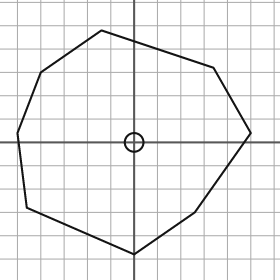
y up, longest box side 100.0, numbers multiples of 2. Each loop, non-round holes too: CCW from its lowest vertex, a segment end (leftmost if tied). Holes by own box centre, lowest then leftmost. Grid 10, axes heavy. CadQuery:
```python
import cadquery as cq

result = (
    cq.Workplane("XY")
    .moveTo(0.0, -48.0)
    .lineTo(26.0, -30.0)
    .lineTo(50.0, 4.0)
    .lineTo(34.0, 32.0)
    .lineTo(-14.0, 48.0)
    .lineTo(-40.0, 30.0)
    .lineTo(-50.0, 4.0)
    .lineTo(-46.0, -28.0)
    .close()
    .moveTo(0.0, 0.0)
    .circle(4.0)
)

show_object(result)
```